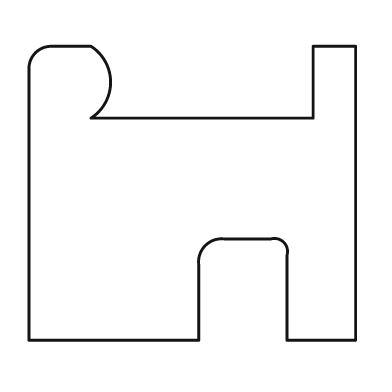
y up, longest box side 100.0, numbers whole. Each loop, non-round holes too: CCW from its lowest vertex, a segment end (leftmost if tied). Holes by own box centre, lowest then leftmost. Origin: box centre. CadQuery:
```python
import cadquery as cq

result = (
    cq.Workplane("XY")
    .moveTo(-50.0, -45.0)
    .lineTo(2.0, -45.0)
    .lineTo(2.0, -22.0)
    .threePointArc((4.0, -16.0), (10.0, -14.0))
    .lineTo(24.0, -14.0)
    .threePointArc((28.0, -15.0), (29.0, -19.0))
    .lineTo(29.0, -45.0)
    .lineTo(50.0, -45.0)
    .lineTo(50.0, 45.0)
    .lineTo(37.0, 45.0)
    .lineTo(37.0, 23.0)
    .lineTo(-31.0, 23.0)
    .threePointArc((-25.0, 34.0), (-31.0, 45.0))
    .lineTo(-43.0, 45.0)
    .threePointArc((-48.0, 43.0), (-50.0, 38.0))
    .close()
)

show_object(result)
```